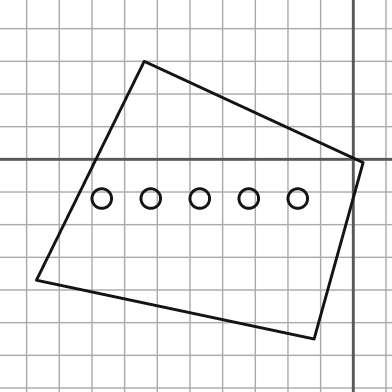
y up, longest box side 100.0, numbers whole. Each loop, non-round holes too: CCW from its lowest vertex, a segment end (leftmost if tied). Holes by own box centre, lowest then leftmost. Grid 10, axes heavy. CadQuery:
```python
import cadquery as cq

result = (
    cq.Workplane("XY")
    .moveTo(-12.0, -55.0)
    .lineTo(3.0, -1.0)
    .lineTo(-64.0, 30.0)
    .lineTo(-97.0, -37.0)
    .close()
    .moveTo(-77.0, -12.0)
    .circle(3.0)
    .moveTo(-62.0, -12.0)
    .circle(3.0)
    .moveTo(-47.0, -12.0)
    .circle(3.0)
    .moveTo(-32.0, -12.0)
    .circle(3.0)
    .moveTo(-17.0, -12.0)
    .circle(3.0)
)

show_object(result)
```